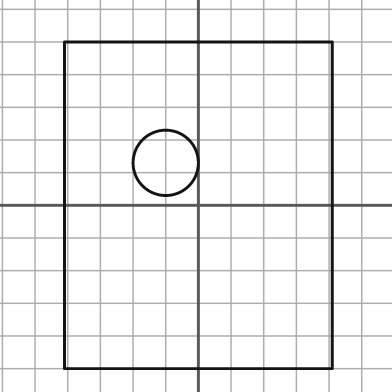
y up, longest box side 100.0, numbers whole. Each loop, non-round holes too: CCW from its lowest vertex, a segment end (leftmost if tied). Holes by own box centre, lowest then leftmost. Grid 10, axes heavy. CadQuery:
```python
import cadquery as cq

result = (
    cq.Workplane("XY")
    .moveTo(-41.0, -50.0)
    .lineTo(41.0, -50.0)
    .lineTo(41.0, 50.0)
    .lineTo(-41.0, 50.0)
    .close()
    .moveTo(-10.0, 13.0)
    .circle(10.0)
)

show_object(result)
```